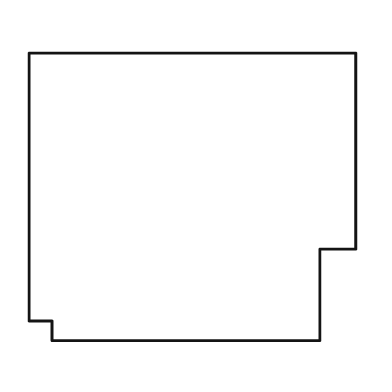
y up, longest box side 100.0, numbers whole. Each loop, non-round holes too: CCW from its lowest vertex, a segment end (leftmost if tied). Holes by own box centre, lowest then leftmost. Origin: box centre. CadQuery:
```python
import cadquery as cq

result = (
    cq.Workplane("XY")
    .moveTo(-43.0, -44.0)
    .lineTo(39.0, -44.0)
    .lineTo(39.0, -16.0)
    .lineTo(50.0, -16.0)
    .lineTo(50.0, 44.0)
    .lineTo(-50.0, 44.0)
    .lineTo(-50.0, -38.0)
    .lineTo(-43.0, -38.0)
    .close()
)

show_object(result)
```